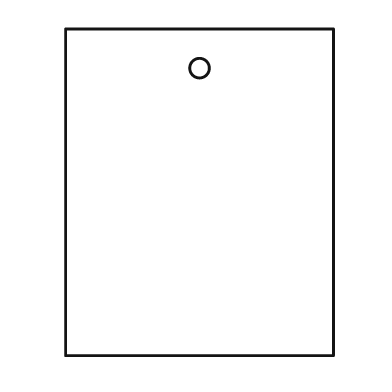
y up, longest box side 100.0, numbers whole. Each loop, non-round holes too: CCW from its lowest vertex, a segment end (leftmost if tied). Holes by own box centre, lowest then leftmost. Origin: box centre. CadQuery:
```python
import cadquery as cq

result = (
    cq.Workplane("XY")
    .moveTo(-41.0, -50.0)
    .lineTo(41.0, -50.0)
    .lineTo(41.0, 50.0)
    .lineTo(-41.0, 50.0)
    .close()
    .moveTo(0.0, 38.0)
    .circle(3.0)
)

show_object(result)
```